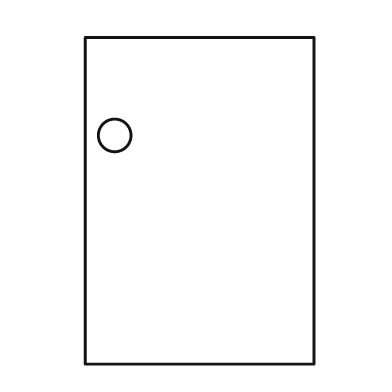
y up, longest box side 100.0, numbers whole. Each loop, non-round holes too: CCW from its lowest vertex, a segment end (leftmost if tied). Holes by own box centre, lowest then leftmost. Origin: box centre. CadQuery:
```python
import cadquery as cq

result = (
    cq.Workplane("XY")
    .moveTo(-35.0, -50.0)
    .lineTo(35.0, -50.0)
    .lineTo(35.0, 50.0)
    .lineTo(-35.0, 50.0)
    .close()
    .moveTo(-26.0, 20.0)
    .circle(5.0)
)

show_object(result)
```